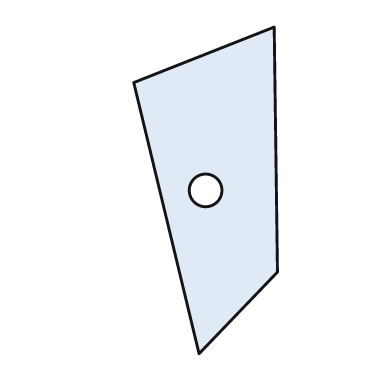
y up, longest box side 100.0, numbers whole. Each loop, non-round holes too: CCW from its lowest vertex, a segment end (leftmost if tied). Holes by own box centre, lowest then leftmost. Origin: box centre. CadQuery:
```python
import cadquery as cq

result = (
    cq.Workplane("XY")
    .moveTo(-2.0, -50.0)
    .lineTo(22.0, -25.0)
    .lineTo(21.0, 50.0)
    .lineTo(-22.0, 33.0)
    .close()
    .moveTo(0.0, 0.0)
    .circle(5.0)
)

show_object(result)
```